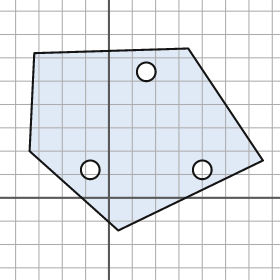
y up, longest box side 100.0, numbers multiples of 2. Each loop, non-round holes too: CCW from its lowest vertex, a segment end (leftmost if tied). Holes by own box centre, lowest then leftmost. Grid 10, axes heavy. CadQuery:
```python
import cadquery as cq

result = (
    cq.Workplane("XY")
    .moveTo(4.0, -14.0)
    .lineTo(66.0, 16.0)
    .lineTo(34.0, 64.0)
    .lineTo(-32.0, 62.0)
    .lineTo(-34.0, 20.0)
    .close()
    .moveTo(-8.0, 12.0)
    .circle(4.0)
    .moveTo(40.0, 12.0)
    .circle(4.0)
    .moveTo(16.0, 54.0)
    .circle(4.0)
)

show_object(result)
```